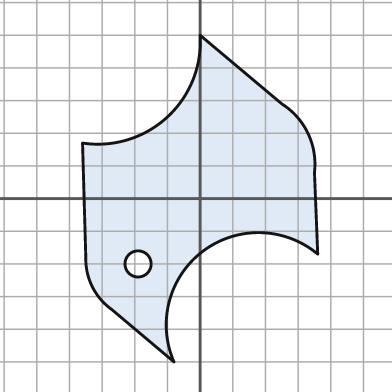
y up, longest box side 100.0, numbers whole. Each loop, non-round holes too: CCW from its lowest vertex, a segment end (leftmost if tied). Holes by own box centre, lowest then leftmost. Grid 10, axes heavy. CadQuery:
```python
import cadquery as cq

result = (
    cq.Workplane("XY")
    .moveTo(-8.0, -50.0)
    .threePointArc((1.0, -16.0), (36.0, -17.0))
    .lineTo(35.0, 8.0)
    .threePointArc((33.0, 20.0), (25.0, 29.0))
    .lineTo(0.0, 50.0)
    .threePointArc((-10.0, 25.0), (-36.0, 17.0))
    .lineTo(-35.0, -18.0)
    .threePointArc((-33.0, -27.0), (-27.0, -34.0))
    .close()
    .moveTo(-19.0, -20.0)
    .circle(4.0)
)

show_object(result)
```